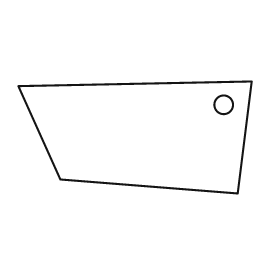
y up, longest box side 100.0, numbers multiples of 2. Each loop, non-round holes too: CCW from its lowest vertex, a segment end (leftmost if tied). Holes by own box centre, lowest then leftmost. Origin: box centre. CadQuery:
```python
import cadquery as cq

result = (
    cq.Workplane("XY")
    .moveTo(44.0, -24.0)
    .lineTo(50.0, 24.0)
    .lineTo(-50.0, 22.0)
    .lineTo(-32.0, -18.0)
    .close()
    .moveTo(38.0, 14.0)
    .circle(4.0)
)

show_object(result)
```